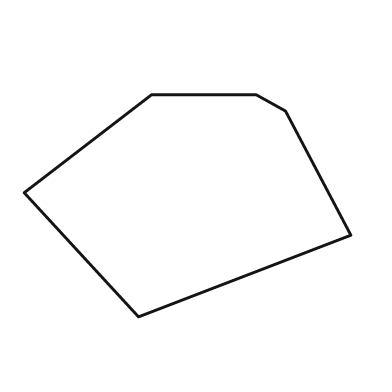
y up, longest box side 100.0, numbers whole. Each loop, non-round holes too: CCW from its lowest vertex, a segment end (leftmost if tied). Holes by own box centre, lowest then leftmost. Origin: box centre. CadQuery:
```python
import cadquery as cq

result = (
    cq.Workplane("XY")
    .moveTo(-15.0, -34.0)
    .lineTo(50.0, -9.0)
    .lineTo(30.0, 29.0)
    .lineTo(21.0, 34.0)
    .lineTo(-11.0, 34.0)
    .lineTo(-50.0, 4.0)
    .close()
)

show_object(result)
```